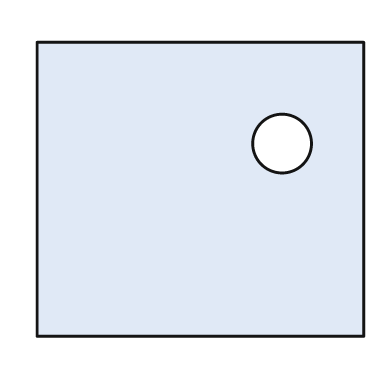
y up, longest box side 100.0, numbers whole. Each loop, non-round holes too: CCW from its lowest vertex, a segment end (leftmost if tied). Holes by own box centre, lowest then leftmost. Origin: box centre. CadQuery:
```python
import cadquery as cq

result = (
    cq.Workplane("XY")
    .moveTo(-50.0, -45.0)
    .lineTo(50.0, -45.0)
    .lineTo(50.0, 45.0)
    .lineTo(-50.0, 45.0)
    .close()
    .moveTo(25.0, 14.0)
    .circle(9.0)
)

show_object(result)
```